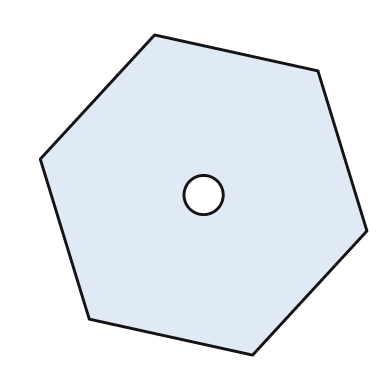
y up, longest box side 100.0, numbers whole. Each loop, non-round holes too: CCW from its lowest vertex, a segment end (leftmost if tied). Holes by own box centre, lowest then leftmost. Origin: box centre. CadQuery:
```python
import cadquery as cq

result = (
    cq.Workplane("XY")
    .moveTo(15.0, -49.0)
    .lineTo(50.0, -11.0)
    .lineTo(35.0, 38.0)
    .lineTo(-15.0, 49.0)
    .lineTo(-50.0, 11.0)
    .lineTo(-35.0, -38.0)
    .close()
    .moveTo(0.0, 0.0)
    .circle(6.0)
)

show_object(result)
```